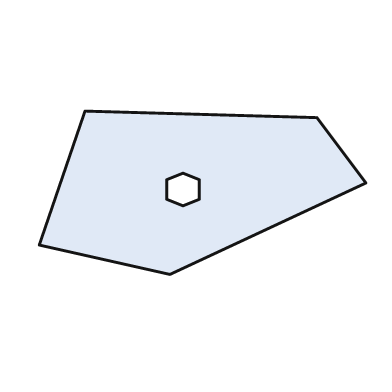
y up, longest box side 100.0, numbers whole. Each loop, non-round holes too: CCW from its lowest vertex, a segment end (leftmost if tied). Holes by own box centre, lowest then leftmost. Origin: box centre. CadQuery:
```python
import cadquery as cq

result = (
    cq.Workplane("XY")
    .moveTo(-10.0, -25.0)
    .lineTo(50.0, 3.0)
    .lineTo(35.0, 23.0)
    .lineTo(-36.0, 25.0)
    .lineTo(-50.0, -16.0)
    .close()
    .moveTo(-6.0, -4.0)
    .lineTo(-1.0, -2.0)
    .lineTo(-1.0, 4.0)
    .lineTo(-6.0, 6.0)
    .lineTo(-11.0, 4.0)
    .lineTo(-11.0, -2.0)
    .close()
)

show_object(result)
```